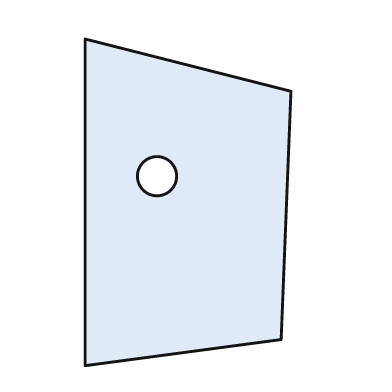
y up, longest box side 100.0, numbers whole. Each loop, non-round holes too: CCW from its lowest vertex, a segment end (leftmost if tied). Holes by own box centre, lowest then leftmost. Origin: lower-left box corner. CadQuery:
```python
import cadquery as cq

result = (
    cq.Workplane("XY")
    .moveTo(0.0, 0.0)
    .lineTo(60.0, 8.0)
    .lineTo(63.0, 84.0)
    .lineTo(0.0, 100.0)
    .close()
    .moveTo(22.0, 58.0)
    .circle(6.0)
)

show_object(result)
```